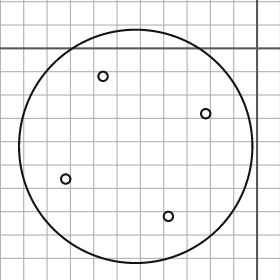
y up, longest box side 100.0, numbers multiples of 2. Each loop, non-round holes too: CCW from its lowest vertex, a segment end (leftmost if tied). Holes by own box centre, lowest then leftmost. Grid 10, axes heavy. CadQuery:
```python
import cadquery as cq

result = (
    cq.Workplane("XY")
    .moveTo(-52.0, -42.0)
    .circle(50.0)
    .moveTo(-38.0, -72.0)
    .circle(2.0)
    .moveTo(-82.0, -56.0)
    .circle(2.0)
    .moveTo(-22.0, -28.0)
    .circle(2.0)
    .moveTo(-66.0, -12.0)
    .circle(2.0)
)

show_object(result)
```